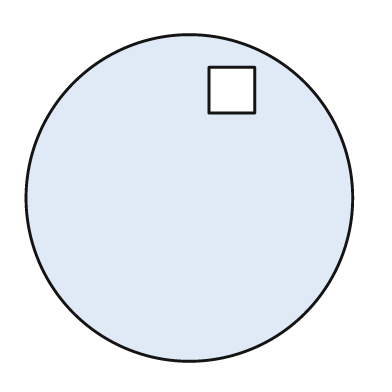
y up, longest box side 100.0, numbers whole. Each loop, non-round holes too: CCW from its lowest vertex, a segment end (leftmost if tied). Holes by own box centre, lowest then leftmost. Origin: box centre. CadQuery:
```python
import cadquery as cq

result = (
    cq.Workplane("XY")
    .moveTo(0.0, 0.0)
    .circle(50.0)
    .moveTo(6.0, 26.0)
    .lineTo(20.0, 26.0)
    .lineTo(20.0, 40.0)
    .lineTo(6.0, 40.0)
    .close()
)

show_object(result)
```